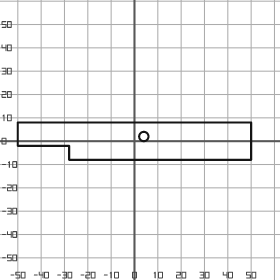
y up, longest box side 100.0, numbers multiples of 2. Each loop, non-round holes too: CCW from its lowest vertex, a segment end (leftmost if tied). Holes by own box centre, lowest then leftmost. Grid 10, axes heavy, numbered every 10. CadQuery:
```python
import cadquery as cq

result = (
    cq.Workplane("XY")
    .moveTo(-28.0, -8.0)
    .lineTo(50.0, -8.0)
    .lineTo(50.0, 8.0)
    .lineTo(-50.0, 8.0)
    .lineTo(-50.0, -2.0)
    .lineTo(-28.0, -2.0)
    .close()
    .moveTo(4.0, 2.0)
    .circle(2.0)
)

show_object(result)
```